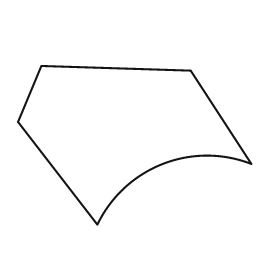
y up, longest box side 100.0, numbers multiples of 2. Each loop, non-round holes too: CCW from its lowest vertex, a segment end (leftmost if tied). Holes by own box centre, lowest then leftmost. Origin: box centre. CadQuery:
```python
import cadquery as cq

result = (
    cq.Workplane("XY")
    .moveTo(-16.0, -34.0)
    .threePointArc((12.0, -8.0), (50.0, -8.0))
    .lineTo(24.0, 32.0)
    .lineTo(-40.0, 34.0)
    .lineTo(-50.0, 10.0)
    .close()
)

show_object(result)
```